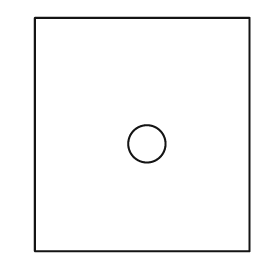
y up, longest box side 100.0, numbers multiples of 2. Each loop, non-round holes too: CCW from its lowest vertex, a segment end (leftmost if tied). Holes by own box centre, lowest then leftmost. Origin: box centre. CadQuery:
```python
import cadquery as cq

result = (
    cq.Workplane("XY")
    .moveTo(-46.0, -50.0)
    .lineTo(46.0, -50.0)
    .lineTo(46.0, 50.0)
    .lineTo(-46.0, 50.0)
    .close()
    .moveTo(2.0, -4.0)
    .circle(8.0)
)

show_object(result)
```